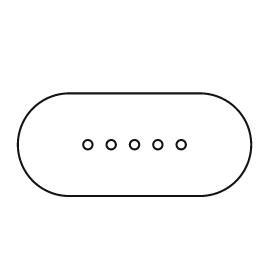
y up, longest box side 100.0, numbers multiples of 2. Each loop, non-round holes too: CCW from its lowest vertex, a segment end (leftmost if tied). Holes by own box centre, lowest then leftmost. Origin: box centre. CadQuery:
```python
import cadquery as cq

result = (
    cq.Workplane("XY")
    .moveTo(-28.0, -22.0)
    .lineTo(28.0, -22.0)
    .threePointArc((50.0, 0.0), (28.0, 22.0))
    .lineTo(-28.0, 22.0)
    .threePointArc((-50.0, 0.0), (-28.0, -22.0))
    .close()
    .moveTo(-20.0, 0.0)
    .circle(2.0)
    .moveTo(-10.0, 0.0)
    .circle(2.0)
    .moveTo(0.0, 0.0)
    .circle(2.0)
    .moveTo(10.0, 0.0)
    .circle(2.0)
    .moveTo(20.0, 0.0)
    .circle(2.0)
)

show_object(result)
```